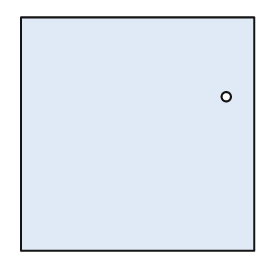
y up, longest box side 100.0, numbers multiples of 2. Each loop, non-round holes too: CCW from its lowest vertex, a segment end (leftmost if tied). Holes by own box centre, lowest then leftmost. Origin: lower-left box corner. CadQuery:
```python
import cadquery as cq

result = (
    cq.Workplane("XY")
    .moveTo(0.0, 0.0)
    .lineTo(100.0, 0.0)
    .lineTo(100.0, 100.0)
    .lineTo(0.0, 100.0)
    .close()
    .moveTo(88.0, 66.0)
    .circle(2.0)
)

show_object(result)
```